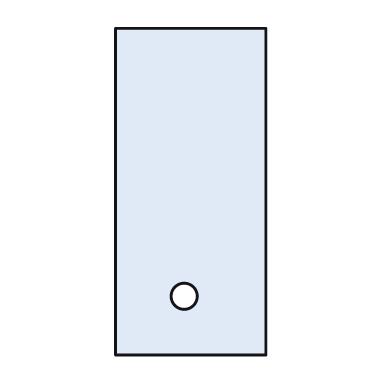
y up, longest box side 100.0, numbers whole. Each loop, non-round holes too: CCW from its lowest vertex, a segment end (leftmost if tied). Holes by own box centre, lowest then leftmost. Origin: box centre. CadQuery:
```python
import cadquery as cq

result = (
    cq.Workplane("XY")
    .moveTo(-23.0, -50.0)
    .lineTo(23.0, -50.0)
    .lineTo(23.0, 50.0)
    .lineTo(-23.0, 50.0)
    .close()
    .moveTo(-2.0, -32.0)
    .circle(4.0)
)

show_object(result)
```